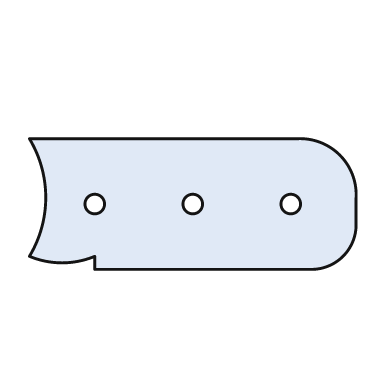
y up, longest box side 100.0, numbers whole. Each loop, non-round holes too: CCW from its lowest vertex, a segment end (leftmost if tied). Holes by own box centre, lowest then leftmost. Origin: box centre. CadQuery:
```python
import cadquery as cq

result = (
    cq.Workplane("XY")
    .moveTo(-30.0, -20.0)
    .lineTo(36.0, -20.0)
    .threePointArc((46.0, -16.0), (50.0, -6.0))
    .lineTo(50.0, 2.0)
    .threePointArc((45.0, 15.0), (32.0, 20.0))
    .lineTo(-50.0, 20.0)
    .threePointArc((-45.0, 2.0), (-50.0, -16.0))
    .threePointArc((-40.0, -18.0), (-30.0, -16.0))
    .close()
    .moveTo(-30.0, 0.0)
    .circle(3.0)
    .moveTo(0.0, 0.0)
    .circle(3.0)
    .moveTo(30.0, 0.0)
    .circle(3.0)
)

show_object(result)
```